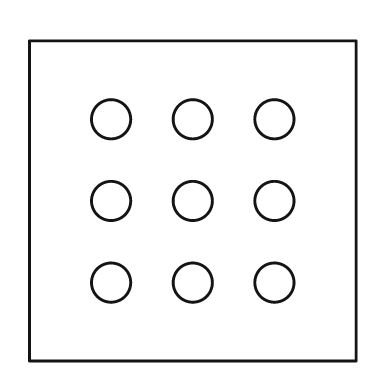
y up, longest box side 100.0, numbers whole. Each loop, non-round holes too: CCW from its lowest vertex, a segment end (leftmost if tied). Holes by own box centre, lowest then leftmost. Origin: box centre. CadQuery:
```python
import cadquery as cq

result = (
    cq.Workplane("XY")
    .moveTo(-50.0, -49.0)
    .lineTo(50.0, -49.0)
    .lineTo(50.0, 49.0)
    .lineTo(-50.0, 49.0)
    .close()
    .moveTo(-25.0, -25.0)
    .circle(6.0)
    .moveTo(0.0, -25.0)
    .circle(6.0)
    .moveTo(25.0, -25.0)
    .circle(6.0)
    .moveTo(-25.0, 0.0)
    .circle(6.0)
    .moveTo(0.0, 0.0)
    .circle(6.0)
    .moveTo(25.0, 0.0)
    .circle(6.0)
    .moveTo(-25.0, 25.0)
    .circle(6.0)
    .moveTo(0.0, 25.0)
    .circle(6.0)
    .moveTo(25.0, 25.0)
    .circle(6.0)
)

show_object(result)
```